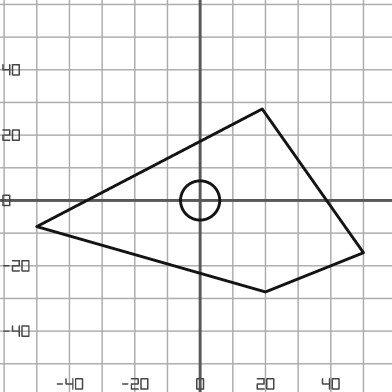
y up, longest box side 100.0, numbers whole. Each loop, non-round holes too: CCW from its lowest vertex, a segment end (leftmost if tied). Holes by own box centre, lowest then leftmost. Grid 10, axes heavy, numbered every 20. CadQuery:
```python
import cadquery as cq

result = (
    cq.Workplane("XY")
    .moveTo(20.0, -28.0)
    .lineTo(50.0, -16.0)
    .lineTo(19.0, 28.0)
    .lineTo(-50.0, -8.0)
    .close()
    .moveTo(0.0, 0.0)
    .circle(6.0)
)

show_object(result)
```